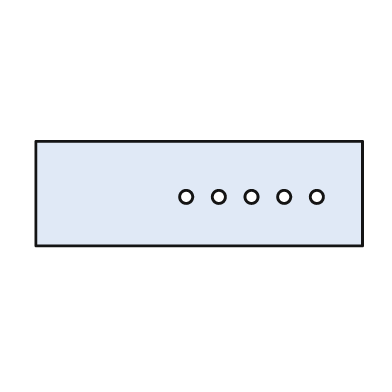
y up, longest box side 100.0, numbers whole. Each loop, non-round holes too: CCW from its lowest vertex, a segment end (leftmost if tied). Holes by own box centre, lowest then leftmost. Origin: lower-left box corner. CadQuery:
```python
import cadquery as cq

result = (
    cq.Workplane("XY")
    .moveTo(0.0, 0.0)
    .lineTo(100.0, 0.0)
    .lineTo(100.0, 32.0)
    .lineTo(0.0, 32.0)
    .close()
    .moveTo(46.0, 15.0)
    .circle(2.0)
    .moveTo(56.0, 15.0)
    .circle(2.0)
    .moveTo(66.0, 15.0)
    .circle(2.0)
    .moveTo(76.0, 15.0)
    .circle(2.0)
    .moveTo(86.0, 15.0)
    .circle(2.0)
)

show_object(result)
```